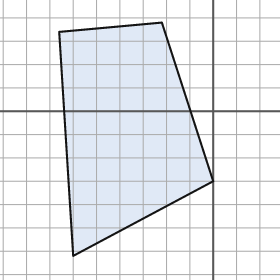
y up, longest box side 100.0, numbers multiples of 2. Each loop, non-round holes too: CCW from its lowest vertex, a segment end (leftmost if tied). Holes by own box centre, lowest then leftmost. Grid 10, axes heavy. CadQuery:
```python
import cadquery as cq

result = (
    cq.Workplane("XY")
    .moveTo(-60.0, -62.0)
    .lineTo(0.0, -30.0)
    .lineTo(-22.0, 38.0)
    .lineTo(-66.0, 34.0)
    .close()
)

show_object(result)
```